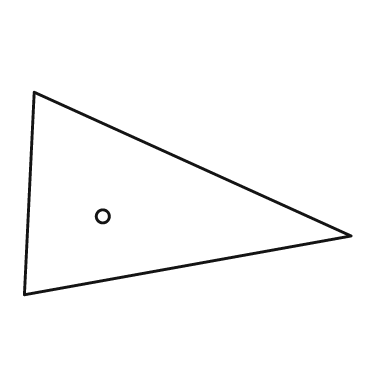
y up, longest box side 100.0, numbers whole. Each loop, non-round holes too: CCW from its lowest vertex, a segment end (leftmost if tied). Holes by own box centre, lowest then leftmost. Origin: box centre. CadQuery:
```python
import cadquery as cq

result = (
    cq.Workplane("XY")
    .moveTo(-50.0, -31.0)
    .lineTo(50.0, -13.0)
    .lineTo(-47.0, 31.0)
    .close()
    .moveTo(-26.0, -7.0)
    .circle(2.0)
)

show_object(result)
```